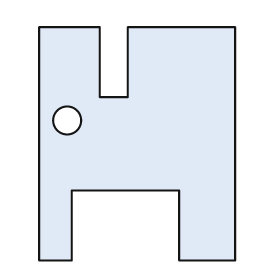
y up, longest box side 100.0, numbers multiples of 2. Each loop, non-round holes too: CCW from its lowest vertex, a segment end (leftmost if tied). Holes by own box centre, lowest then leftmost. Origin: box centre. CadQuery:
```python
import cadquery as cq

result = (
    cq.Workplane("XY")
    .moveTo(-42.0, -50.0)
    .lineTo(-28.0, -50.0)
    .lineTo(-28.0, -20.0)
    .lineTo(18.0, -20.0)
    .lineTo(18.0, -50.0)
    .lineTo(42.0, -50.0)
    .lineTo(42.0, 50.0)
    .lineTo(-4.0, 50.0)
    .lineTo(-4.0, 20.0)
    .lineTo(-16.0, 20.0)
    .lineTo(-16.0, 50.0)
    .lineTo(-42.0, 50.0)
    .close()
    .moveTo(-30.0, 10.0)
    .circle(6.0)
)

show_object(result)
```